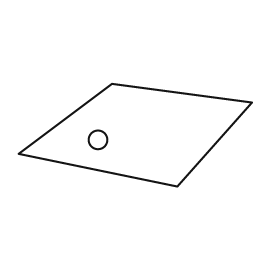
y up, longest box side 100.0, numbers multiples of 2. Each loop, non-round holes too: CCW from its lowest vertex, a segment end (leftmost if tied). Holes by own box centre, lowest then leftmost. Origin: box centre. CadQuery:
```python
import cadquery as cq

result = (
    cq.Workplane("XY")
    .moveTo(18.0, -22.0)
    .lineTo(50.0, 14.0)
    .lineTo(-10.0, 22.0)
    .lineTo(-50.0, -8.0)
    .close()
    .moveTo(-16.0, -2.0)
    .circle(4.0)
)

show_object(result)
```